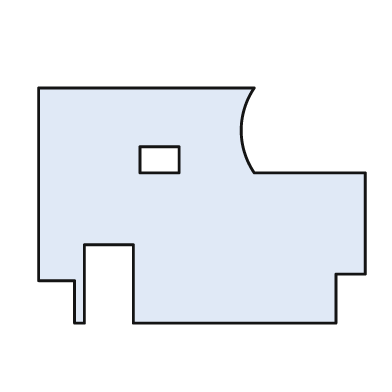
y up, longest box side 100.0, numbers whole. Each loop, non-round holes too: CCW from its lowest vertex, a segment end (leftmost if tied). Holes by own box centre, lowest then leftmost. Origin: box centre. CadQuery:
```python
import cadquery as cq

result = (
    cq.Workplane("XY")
    .moveTo(-39.0, -36.0)
    .lineTo(-36.0, -36.0)
    .lineTo(-36.0, -12.0)
    .lineTo(-21.0, -12.0)
    .lineTo(-21.0, -36.0)
    .lineTo(41.0, -36.0)
    .lineTo(41.0, -21.0)
    .lineTo(50.0, -21.0)
    .lineTo(50.0, 10.0)
    .lineTo(16.0, 10.0)
    .threePointArc((12.0, 23.0), (16.0, 36.0))
    .lineTo(-50.0, 36.0)
    .lineTo(-50.0, -23.0)
    .lineTo(-39.0, -23.0)
    .close()
    .moveTo(-19.0, 10.0)
    .lineTo(-7.0, 10.0)
    .lineTo(-7.0, 18.0)
    .lineTo(-19.0, 18.0)
    .close()
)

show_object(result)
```